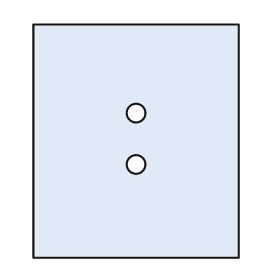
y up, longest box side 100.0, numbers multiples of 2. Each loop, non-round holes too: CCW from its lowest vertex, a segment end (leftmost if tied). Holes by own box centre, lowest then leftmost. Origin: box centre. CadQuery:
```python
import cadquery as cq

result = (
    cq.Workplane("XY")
    .moveTo(-44.0, -50.0)
    .lineTo(44.0, -50.0)
    .lineTo(44.0, 50.0)
    .lineTo(-44.0, 50.0)
    .close()
    .moveTo(0.0, -10.0)
    .circle(4.0)
    .moveTo(0.0, 12.0)
    .circle(4.0)
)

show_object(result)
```